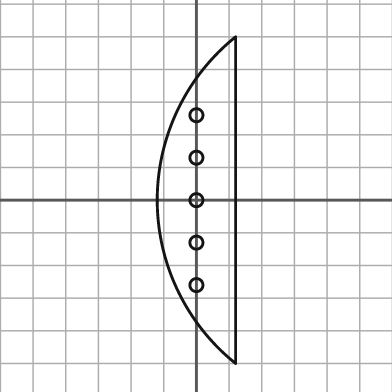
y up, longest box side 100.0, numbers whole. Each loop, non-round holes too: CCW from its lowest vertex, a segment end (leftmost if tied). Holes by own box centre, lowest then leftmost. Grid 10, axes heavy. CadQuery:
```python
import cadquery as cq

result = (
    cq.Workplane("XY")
    .moveTo(12.0, -50.0)
    .lineTo(12.0, 50.0)
    .threePointArc((-12.0, 0.0), (12.0, -50.0))
    .close()
    .moveTo(0.0, -26.0)
    .circle(2.0)
    .moveTo(0.0, -13.0)
    .circle(2.0)
    .moveTo(0.0, 0.0)
    .circle(2.0)
    .moveTo(0.0, 13.0)
    .circle(2.0)
    .moveTo(0.0, 26.0)
    .circle(2.0)
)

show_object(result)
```